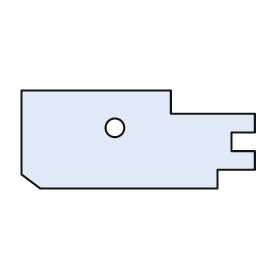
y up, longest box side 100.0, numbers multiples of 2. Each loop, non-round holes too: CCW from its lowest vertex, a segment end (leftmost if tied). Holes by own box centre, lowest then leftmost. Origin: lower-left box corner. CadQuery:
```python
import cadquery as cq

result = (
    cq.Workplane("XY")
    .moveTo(8.0, 0.0)
    .lineTo(84.0, 0.0)
    .lineTo(84.0, 8.0)
    .lineTo(100.0, 8.0)
    .lineTo(100.0, 16.0)
    .lineTo(90.0, 16.0)
    .lineTo(90.0, 24.0)
    .lineTo(100.0, 24.0)
    .lineTo(100.0, 32.0)
    .lineTo(64.0, 32.0)
    .lineTo(64.0, 42.0)
    .lineTo(0.0, 42.0)
    .lineTo(0.0, 6.0)
    .close()
    .moveTo(40.0, 26.0)
    .circle(4.0)
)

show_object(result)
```